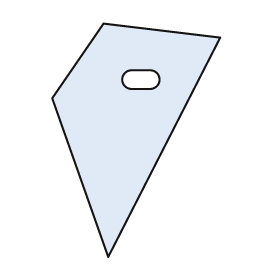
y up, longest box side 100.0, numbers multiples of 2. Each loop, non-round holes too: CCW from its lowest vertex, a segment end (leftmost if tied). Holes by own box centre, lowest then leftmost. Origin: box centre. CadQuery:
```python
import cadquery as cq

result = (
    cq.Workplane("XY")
    .moveTo(-12.0, -50.0)
    .lineTo(36.0, 44.0)
    .lineTo(-14.0, 50.0)
    .lineTo(-36.0, 18.0)
    .close()
    .moveTo(-2.0, 22.0)
    .lineTo(6.0, 22.0)
    .threePointArc((10.0, 26.0), (6.0, 30.0))
    .lineTo(-2.0, 30.0)
    .threePointArc((-6.0, 26.0), (-2.0, 22.0))
    .close()
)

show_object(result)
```